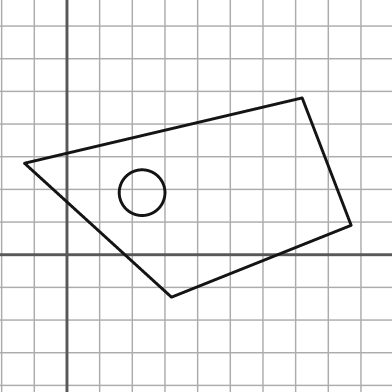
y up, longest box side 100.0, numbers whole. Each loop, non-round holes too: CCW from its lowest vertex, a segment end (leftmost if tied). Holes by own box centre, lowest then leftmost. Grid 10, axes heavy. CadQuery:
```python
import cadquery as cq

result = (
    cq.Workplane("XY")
    .moveTo(32.0, -13.0)
    .lineTo(87.0, 9.0)
    .lineTo(72.0, 48.0)
    .lineTo(-13.0, 28.0)
    .close()
    .moveTo(23.0, 19.0)
    .circle(7.0)
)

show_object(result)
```